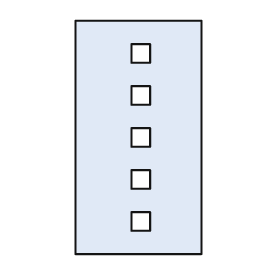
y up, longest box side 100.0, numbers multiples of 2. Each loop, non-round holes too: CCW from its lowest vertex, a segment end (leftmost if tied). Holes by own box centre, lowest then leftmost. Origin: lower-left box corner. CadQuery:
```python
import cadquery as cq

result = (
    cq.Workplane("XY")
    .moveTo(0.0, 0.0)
    .lineTo(54.0, 0.0)
    .lineTo(54.0, 100.0)
    .lineTo(0.0, 100.0)
    .close()
    .moveTo(24.0, 10.0)
    .lineTo(32.0, 10.0)
    .lineTo(32.0, 18.0)
    .lineTo(24.0, 18.0)
    .close()
    .moveTo(24.0, 28.0)
    .lineTo(32.0, 28.0)
    .lineTo(32.0, 36.0)
    .lineTo(24.0, 36.0)
    .close()
    .moveTo(24.0, 46.0)
    .lineTo(32.0, 46.0)
    .lineTo(32.0, 54.0)
    .lineTo(24.0, 54.0)
    .close()
    .moveTo(24.0, 64.0)
    .lineTo(32.0, 64.0)
    .lineTo(32.0, 72.0)
    .lineTo(24.0, 72.0)
    .close()
    .moveTo(24.0, 82.0)
    .lineTo(32.0, 82.0)
    .lineTo(32.0, 90.0)
    .lineTo(24.0, 90.0)
    .close()
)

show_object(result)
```